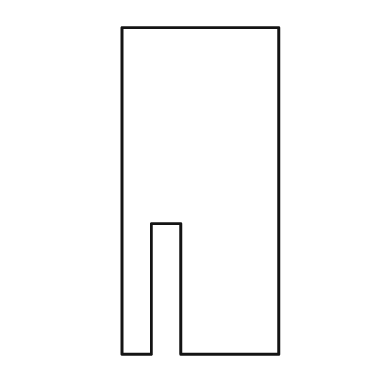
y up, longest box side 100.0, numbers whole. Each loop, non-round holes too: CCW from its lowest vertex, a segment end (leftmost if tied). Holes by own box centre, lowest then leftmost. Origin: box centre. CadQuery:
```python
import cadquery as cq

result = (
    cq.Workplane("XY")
    .moveTo(-24.0, -50.0)
    .lineTo(-15.0, -50.0)
    .lineTo(-15.0, -10.0)
    .lineTo(-6.0, -10.0)
    .lineTo(-6.0, -50.0)
    .lineTo(24.0, -50.0)
    .lineTo(24.0, 50.0)
    .lineTo(-24.0, 50.0)
    .close()
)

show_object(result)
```